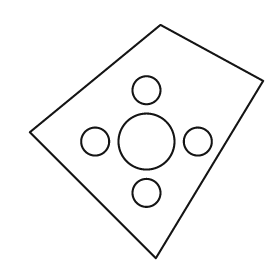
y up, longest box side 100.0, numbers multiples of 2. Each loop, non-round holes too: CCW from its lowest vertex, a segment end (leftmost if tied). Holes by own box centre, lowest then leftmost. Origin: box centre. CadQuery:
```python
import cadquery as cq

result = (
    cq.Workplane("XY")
    .moveTo(4.0, -50.0)
    .lineTo(50.0, 26.0)
    .lineTo(6.0, 50.0)
    .lineTo(-50.0, 4.0)
    .close()
    .moveTo(0.0, -22.0)
    .circle(6.0)
    .moveTo(-22.0, 0.0)
    .circle(6.0)
    .moveTo(0.0, 0.0)
    .circle(12.0)
    .moveTo(22.0, 0.0)
    .circle(6.0)
    .moveTo(0.0, 22.0)
    .circle(6.0)
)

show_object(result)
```